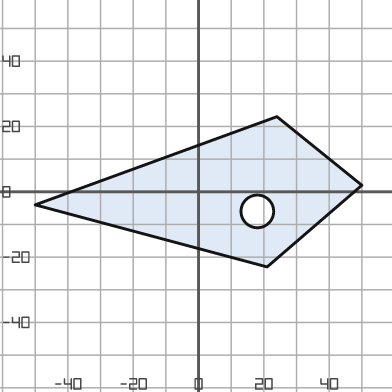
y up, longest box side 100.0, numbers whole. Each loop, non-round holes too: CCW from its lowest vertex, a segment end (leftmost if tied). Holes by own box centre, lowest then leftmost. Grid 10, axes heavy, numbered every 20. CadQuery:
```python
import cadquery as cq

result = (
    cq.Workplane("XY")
    .moveTo(21.0, -23.0)
    .lineTo(50.0, 2.0)
    .lineTo(24.0, 23.0)
    .lineTo(-50.0, -4.0)
    .close()
    .moveTo(18.0, -6.0)
    .circle(5.0)
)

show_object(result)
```